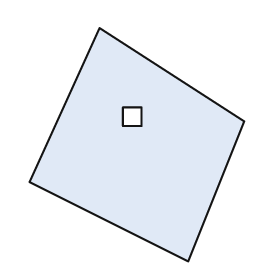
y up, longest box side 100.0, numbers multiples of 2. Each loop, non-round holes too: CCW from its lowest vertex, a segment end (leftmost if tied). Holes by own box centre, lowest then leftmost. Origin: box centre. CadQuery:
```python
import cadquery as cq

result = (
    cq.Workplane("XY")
    .moveTo(22.0, -50.0)
    .lineTo(46.0, 10.0)
    .lineTo(-16.0, 50.0)
    .lineTo(-46.0, -16.0)
    .close()
    .moveTo(-6.0, 8.0)
    .lineTo(2.0, 8.0)
    .lineTo(2.0, 16.0)
    .lineTo(-6.0, 16.0)
    .close()
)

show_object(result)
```